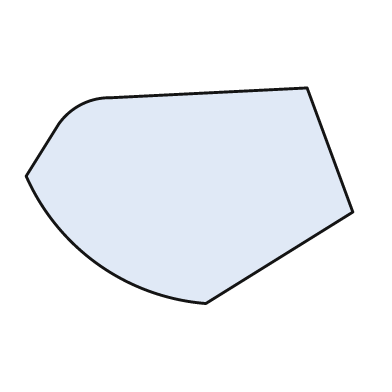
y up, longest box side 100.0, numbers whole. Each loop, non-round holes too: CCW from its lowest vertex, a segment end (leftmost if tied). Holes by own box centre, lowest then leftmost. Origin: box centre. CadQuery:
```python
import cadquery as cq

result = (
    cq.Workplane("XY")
    .moveTo(5.0, -33.0)
    .lineTo(50.0, -5.0)
    .lineTo(36.0, 33.0)
    .lineTo(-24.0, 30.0)
    .threePointArc((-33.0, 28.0), (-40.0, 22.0))
    .lineTo(-50.0, 6.0)
    .threePointArc((-28.0, -21.0), (5.0, -33.0))
    .close()
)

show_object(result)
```